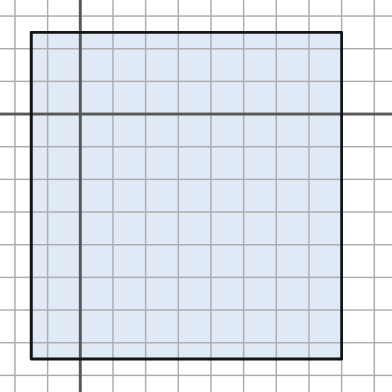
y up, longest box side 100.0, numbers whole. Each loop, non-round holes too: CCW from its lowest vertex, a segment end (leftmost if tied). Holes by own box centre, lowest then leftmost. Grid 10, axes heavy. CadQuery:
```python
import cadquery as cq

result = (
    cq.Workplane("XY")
    .moveTo(-15.0, -75.0)
    .lineTo(80.0, -75.0)
    .lineTo(80.0, 25.0)
    .lineTo(-15.0, 25.0)
    .close()
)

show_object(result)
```